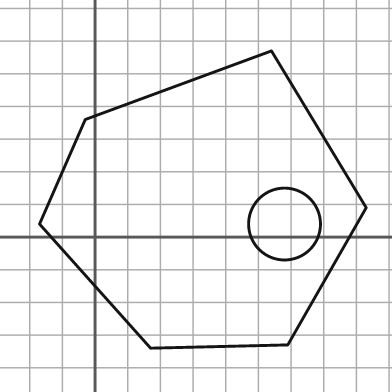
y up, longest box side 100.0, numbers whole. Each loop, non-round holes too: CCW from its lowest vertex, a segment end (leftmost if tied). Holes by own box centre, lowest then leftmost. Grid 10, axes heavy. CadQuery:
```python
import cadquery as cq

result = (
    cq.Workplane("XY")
    .moveTo(17.0, -34.0)
    .lineTo(59.0, -33.0)
    .lineTo(83.0, 9.0)
    .lineTo(54.0, 57.0)
    .lineTo(-3.0, 36.0)
    .lineTo(-17.0, 4.0)
    .close()
    .moveTo(58.0, 4.0)
    .circle(11.0)
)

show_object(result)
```